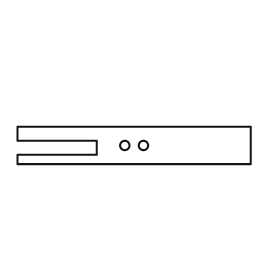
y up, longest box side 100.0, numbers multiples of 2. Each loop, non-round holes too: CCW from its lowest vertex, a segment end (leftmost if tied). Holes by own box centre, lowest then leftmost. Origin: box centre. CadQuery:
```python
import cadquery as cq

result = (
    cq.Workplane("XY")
    .moveTo(-50.0, -8.0)
    .lineTo(50.0, -8.0)
    .lineTo(50.0, 8.0)
    .lineTo(-50.0, 8.0)
    .lineTo(-50.0, 2.0)
    .lineTo(-16.0, 2.0)
    .lineTo(-16.0, -4.0)
    .lineTo(-50.0, -4.0)
    .close()
    .moveTo(-4.0, 0.0)
    .circle(2.0)
    .moveTo(4.0, 0.0)
    .circle(2.0)
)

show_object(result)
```